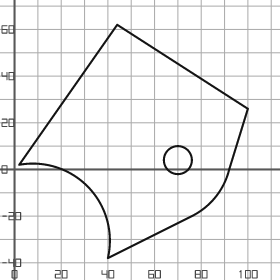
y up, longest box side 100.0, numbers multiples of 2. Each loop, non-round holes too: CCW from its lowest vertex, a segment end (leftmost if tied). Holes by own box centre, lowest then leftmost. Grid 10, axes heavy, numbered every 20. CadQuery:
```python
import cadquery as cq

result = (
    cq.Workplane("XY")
    .moveTo(40.0, -38.0)
    .lineTo(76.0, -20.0)
    .threePointArc((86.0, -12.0), (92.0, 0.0))
    .lineTo(100.0, 26.0)
    .lineTo(44.0, 62.0)
    .lineTo(2.0, 2.0)
    .threePointArc((32.0, -8.0), (40.0, -38.0))
    .close()
    .moveTo(70.0, 4.0)
    .circle(6.0)
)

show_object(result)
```